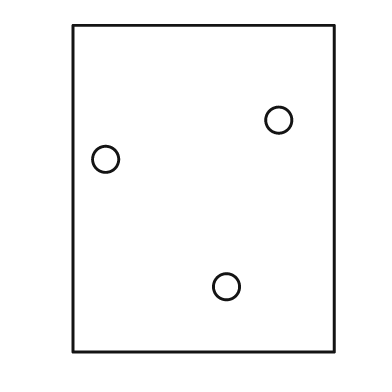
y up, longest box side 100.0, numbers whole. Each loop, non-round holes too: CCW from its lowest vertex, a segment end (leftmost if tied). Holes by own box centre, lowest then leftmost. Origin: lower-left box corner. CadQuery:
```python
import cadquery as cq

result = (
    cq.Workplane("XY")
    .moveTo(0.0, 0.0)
    .lineTo(80.0, 0.0)
    .lineTo(80.0, 100.0)
    .lineTo(0.0, 100.0)
    .close()
    .moveTo(47.0, 20.0)
    .circle(4.0)
    .moveTo(10.0, 59.0)
    .circle(4.0)
    .moveTo(63.0, 71.0)
    .circle(4.0)
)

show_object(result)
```